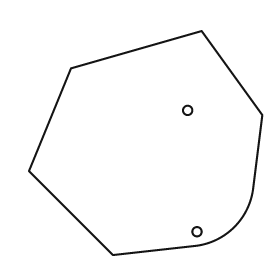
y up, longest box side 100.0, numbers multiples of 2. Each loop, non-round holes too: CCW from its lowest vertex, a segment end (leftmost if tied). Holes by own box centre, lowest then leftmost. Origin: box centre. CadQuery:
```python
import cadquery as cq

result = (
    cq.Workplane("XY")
    .moveTo(-14.0, -48.0)
    .lineTo(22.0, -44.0)
    .threePointArc((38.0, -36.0), (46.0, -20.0))
    .lineTo(50.0, 12.0)
    .lineTo(24.0, 48.0)
    .lineTo(-32.0, 32.0)
    .lineTo(-50.0, -12.0)
    .close()
    .moveTo(22.0, -38.0)
    .circle(2.0)
    .moveTo(18.0, 14.0)
    .circle(2.0)
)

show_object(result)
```